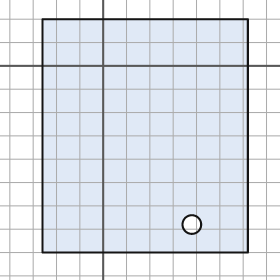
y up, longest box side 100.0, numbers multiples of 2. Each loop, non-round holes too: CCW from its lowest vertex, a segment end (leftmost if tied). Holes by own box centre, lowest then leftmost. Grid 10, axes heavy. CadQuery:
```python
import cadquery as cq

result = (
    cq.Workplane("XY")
    .moveTo(-26.0, -80.0)
    .lineTo(62.0, -80.0)
    .lineTo(62.0, 20.0)
    .lineTo(-26.0, 20.0)
    .close()
    .moveTo(38.0, -68.0)
    .circle(4.0)
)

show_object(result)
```